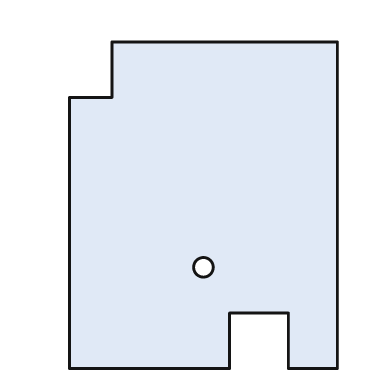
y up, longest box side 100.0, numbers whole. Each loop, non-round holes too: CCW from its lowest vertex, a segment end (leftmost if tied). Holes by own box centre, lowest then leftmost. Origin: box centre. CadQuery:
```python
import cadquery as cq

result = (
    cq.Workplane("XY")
    .moveTo(-41.0, -50.0)
    .lineTo(8.0, -50.0)
    .lineTo(8.0, -33.0)
    .lineTo(26.0, -33.0)
    .lineTo(26.0, -50.0)
    .lineTo(41.0, -50.0)
    .lineTo(41.0, 50.0)
    .lineTo(-28.0, 50.0)
    .lineTo(-28.0, 33.0)
    .lineTo(-41.0, 33.0)
    .close()
    .moveTo(0.0, -19.0)
    .circle(3.0)
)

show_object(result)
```